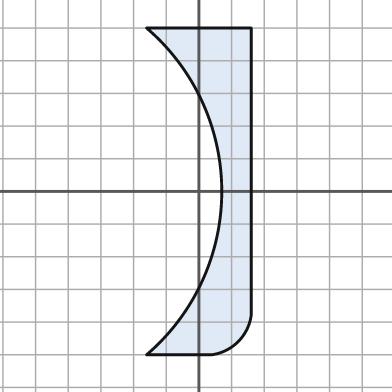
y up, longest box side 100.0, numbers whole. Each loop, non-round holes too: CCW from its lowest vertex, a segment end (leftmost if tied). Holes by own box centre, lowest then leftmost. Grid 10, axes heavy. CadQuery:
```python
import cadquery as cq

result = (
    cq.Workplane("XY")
    .moveTo(-16.0, -50.0)
    .lineTo(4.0, -50.0)
    .threePointArc((12.0, -46.0), (16.0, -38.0))
    .lineTo(16.0, 50.0)
    .lineTo(-16.0, 50.0)
    .threePointArc((7.0, 0.0), (-16.0, -50.0))
    .close()
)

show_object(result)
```